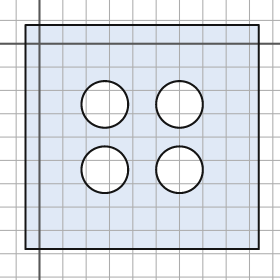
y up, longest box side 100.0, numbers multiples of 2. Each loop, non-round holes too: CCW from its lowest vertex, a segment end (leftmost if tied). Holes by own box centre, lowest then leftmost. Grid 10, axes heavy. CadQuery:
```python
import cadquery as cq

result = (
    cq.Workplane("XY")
    .moveTo(-6.0, -88.0)
    .lineTo(94.0, -88.0)
    .lineTo(94.0, 8.0)
    .lineTo(-6.0, 8.0)
    .close()
    .moveTo(28.0, -54.0)
    .circle(10.0)
    .moveTo(60.0, -54.0)
    .circle(10.0)
    .moveTo(28.0, -26.0)
    .circle(10.0)
    .moveTo(60.0, -26.0)
    .circle(10.0)
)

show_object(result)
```